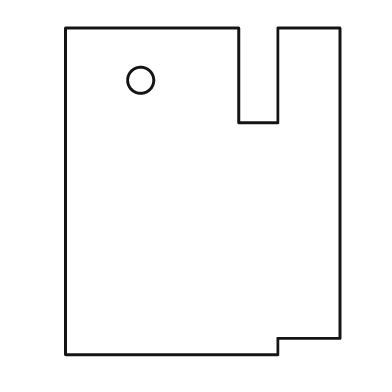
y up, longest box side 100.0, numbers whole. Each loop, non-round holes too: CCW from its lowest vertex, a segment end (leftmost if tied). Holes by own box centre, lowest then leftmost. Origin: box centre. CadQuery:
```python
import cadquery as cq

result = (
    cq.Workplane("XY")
    .moveTo(-42.0, -50.0)
    .lineTo(23.0, -50.0)
    .lineTo(23.0, -45.0)
    .lineTo(42.0, -45.0)
    .lineTo(42.0, 50.0)
    .lineTo(23.0, 50.0)
    .lineTo(23.0, 21.0)
    .lineTo(11.0, 21.0)
    .lineTo(11.0, 50.0)
    .lineTo(-42.0, 50.0)
    .close()
    .moveTo(-19.0, 34.0)
    .circle(4.0)
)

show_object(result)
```